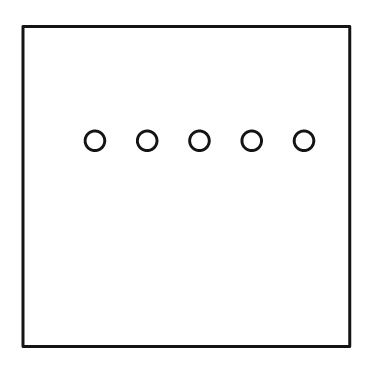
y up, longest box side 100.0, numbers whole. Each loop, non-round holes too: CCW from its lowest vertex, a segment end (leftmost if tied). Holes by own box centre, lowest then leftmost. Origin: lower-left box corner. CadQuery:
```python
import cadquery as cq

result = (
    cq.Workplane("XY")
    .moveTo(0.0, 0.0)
    .lineTo(100.0, 0.0)
    .lineTo(100.0, 98.0)
    .lineTo(0.0, 98.0)
    .close()
    .moveTo(22.0, 63.0)
    .circle(3.0)
    .moveTo(38.0, 63.0)
    .circle(3.0)
    .moveTo(54.0, 63.0)
    .circle(3.0)
    .moveTo(70.0, 63.0)
    .circle(3.0)
    .moveTo(86.0, 63.0)
    .circle(3.0)
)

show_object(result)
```